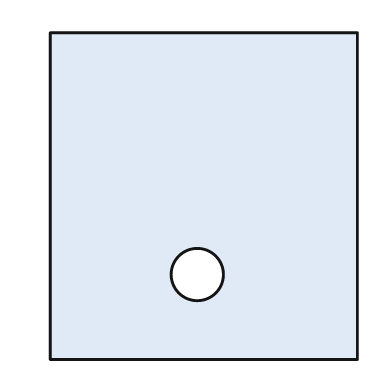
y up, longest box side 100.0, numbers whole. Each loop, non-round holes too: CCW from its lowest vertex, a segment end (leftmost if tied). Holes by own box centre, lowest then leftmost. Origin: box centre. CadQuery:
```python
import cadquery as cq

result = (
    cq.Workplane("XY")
    .moveTo(-47.0, -50.0)
    .lineTo(47.0, -50.0)
    .lineTo(47.0, 50.0)
    .lineTo(-47.0, 50.0)
    .close()
    .moveTo(-2.0, -24.0)
    .circle(8.0)
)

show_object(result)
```